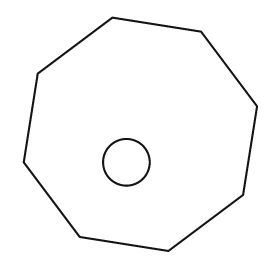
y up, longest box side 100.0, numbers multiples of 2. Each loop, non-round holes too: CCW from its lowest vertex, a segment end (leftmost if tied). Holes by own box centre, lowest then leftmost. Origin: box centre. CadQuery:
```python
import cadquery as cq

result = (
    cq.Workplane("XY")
    .moveTo(12.0, -50.0)
    .lineTo(44.0, -26.0)
    .lineTo(50.0, 12.0)
    .lineTo(26.0, 44.0)
    .lineTo(-12.0, 50.0)
    .lineTo(-44.0, 26.0)
    .lineTo(-50.0, -12.0)
    .lineTo(-26.0, -44.0)
    .close()
    .moveTo(-6.0, -12.0)
    .circle(10.0)
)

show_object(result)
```